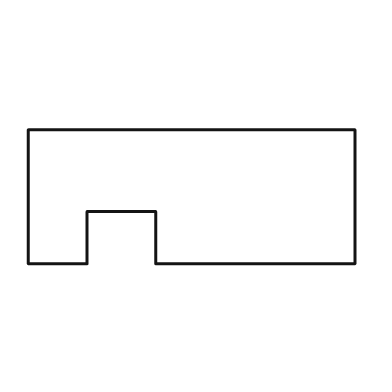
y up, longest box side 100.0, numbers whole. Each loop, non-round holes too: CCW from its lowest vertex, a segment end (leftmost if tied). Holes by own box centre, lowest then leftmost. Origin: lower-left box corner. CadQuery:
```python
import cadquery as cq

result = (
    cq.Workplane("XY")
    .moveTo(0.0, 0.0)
    .lineTo(18.0, 0.0)
    .lineTo(18.0, 16.0)
    .lineTo(39.0, 16.0)
    .lineTo(39.0, 0.0)
    .lineTo(100.0, 0.0)
    .lineTo(100.0, 41.0)
    .lineTo(0.0, 41.0)
    .close()
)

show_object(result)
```